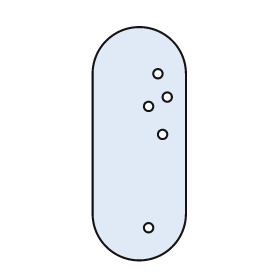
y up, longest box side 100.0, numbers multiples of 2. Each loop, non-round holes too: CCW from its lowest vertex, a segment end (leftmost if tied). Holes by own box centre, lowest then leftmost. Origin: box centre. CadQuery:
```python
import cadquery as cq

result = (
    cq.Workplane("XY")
    .moveTo(-20.0, -30.0)
    .threePointArc((0.0, -50.0), (20.0, -30.0))
    .lineTo(20.0, 30.0)
    .threePointArc((0.0, 50.0), (-20.0, 30.0))
    .close()
    .moveTo(4.0, -36.0)
    .circle(2.0)
    .moveTo(10.0, 4.0)
    .circle(2.0)
    .moveTo(4.0, 16.0)
    .circle(2.0)
    .moveTo(12.0, 20.0)
    .circle(2.0)
    .moveTo(8.0, 30.0)
    .circle(2.0)
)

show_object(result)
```